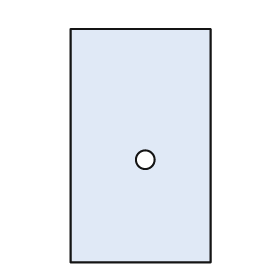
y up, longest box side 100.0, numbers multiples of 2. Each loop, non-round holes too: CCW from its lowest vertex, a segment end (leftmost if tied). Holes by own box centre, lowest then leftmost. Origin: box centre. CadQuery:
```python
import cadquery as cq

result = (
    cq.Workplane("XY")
    .moveTo(-30.0, -50.0)
    .lineTo(30.0, -50.0)
    .lineTo(30.0, 50.0)
    .lineTo(-30.0, 50.0)
    .close()
    .moveTo(2.0, -6.0)
    .circle(4.0)
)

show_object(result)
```